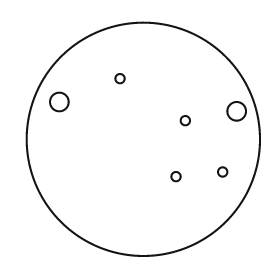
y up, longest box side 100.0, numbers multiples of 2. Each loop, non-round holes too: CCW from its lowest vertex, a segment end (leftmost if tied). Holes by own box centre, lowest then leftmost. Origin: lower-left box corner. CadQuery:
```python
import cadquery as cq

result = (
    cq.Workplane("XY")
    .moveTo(50.0, 50.0)
    .circle(50.0)
    .moveTo(64.0, 34.0)
    .circle(2.0)
    .moveTo(84.0, 36.0)
    .circle(2.0)
    .moveTo(68.0, 58.0)
    .circle(2.0)
    .moveTo(90.0, 62.0)
    .circle(4.0)
    .moveTo(14.0, 66.0)
    .circle(4.0)
    .moveTo(40.0, 76.0)
    .circle(2.0)
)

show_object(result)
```